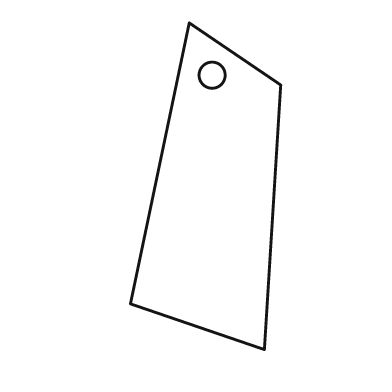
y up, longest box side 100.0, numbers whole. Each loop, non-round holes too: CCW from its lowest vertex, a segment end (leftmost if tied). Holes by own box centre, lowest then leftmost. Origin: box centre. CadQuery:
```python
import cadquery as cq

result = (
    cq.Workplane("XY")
    .moveTo(18.0, -50.0)
    .lineTo(23.0, 31.0)
    .lineTo(-5.0, 50.0)
    .lineTo(-23.0, -36.0)
    .close()
    .moveTo(2.0, 34.0)
    .circle(4.0)
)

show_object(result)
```